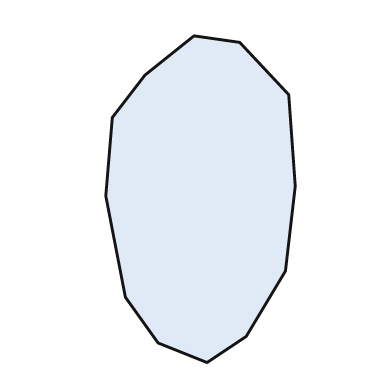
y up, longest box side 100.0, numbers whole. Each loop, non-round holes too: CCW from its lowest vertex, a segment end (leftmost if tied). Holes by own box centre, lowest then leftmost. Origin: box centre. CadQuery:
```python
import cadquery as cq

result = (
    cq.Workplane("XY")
    .moveTo(2.0, -50.0)
    .lineTo(14.0, -42.0)
    .lineTo(26.0, -22.0)
    .lineTo(29.0, 4.0)
    .lineTo(27.0, 32.0)
    .lineTo(12.0, 48.0)
    .lineTo(-2.0, 50.0)
    .lineTo(-17.0, 38.0)
    .lineTo(-27.0, 25.0)
    .lineTo(-29.0, 1.0)
    .lineTo(-23.0, -30.0)
    .lineTo(-13.0, -44.0)
    .close()
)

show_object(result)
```